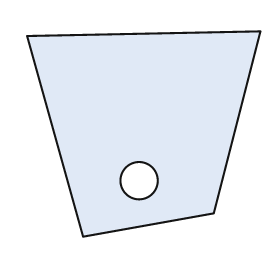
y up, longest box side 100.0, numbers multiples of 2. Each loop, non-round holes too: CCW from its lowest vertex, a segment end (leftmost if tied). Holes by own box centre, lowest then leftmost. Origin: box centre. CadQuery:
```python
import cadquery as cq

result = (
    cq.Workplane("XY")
    .moveTo(-26.0, -44.0)
    .lineTo(30.0, -34.0)
    .lineTo(50.0, 44.0)
    .lineTo(-50.0, 42.0)
    .close()
    .moveTo(-2.0, -20.0)
    .circle(8.0)
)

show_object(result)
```